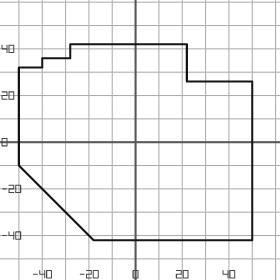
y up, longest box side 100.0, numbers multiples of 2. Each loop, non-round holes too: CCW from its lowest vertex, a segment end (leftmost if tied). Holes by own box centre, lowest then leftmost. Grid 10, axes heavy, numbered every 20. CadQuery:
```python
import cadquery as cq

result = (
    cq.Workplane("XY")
    .moveTo(-18.0, -42.0)
    .lineTo(50.0, -42.0)
    .lineTo(50.0, 26.0)
    .lineTo(22.0, 26.0)
    .lineTo(22.0, 42.0)
    .lineTo(-28.0, 42.0)
    .lineTo(-28.0, 36.0)
    .lineTo(-40.0, 36.0)
    .lineTo(-40.0, 32.0)
    .lineTo(-50.0, 32.0)
    .lineTo(-50.0, -10.0)
    .close()
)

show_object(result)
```